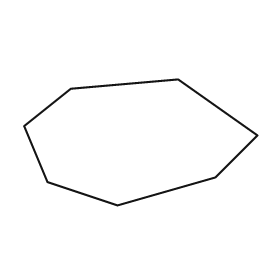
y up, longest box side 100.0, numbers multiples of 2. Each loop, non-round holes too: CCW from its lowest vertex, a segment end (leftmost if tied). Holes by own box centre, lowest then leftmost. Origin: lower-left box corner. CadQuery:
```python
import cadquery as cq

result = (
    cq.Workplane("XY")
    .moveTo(40.0, 0.0)
    .lineTo(82.0, 12.0)
    .lineTo(100.0, 30.0)
    .lineTo(66.0, 54.0)
    .lineTo(20.0, 50.0)
    .lineTo(0.0, 34.0)
    .lineTo(10.0, 10.0)
    .close()
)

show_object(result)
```